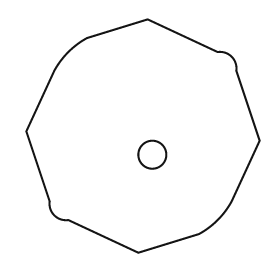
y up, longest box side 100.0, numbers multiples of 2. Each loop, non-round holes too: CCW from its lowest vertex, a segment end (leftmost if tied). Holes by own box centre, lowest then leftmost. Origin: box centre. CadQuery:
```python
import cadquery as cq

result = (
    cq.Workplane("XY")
    .moveTo(-2.0, -50.0)
    .lineTo(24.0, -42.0)
    .threePointArc((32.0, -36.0), (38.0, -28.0))
    .lineTo(50.0, -2.0)
    .lineTo(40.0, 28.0)
    .threePointArc((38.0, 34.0), (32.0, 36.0))
    .lineTo(2.0, 50.0)
    .lineTo(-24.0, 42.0)
    .threePointArc((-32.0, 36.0), (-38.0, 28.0))
    .lineTo(-50.0, 2.0)
    .lineTo(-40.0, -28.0)
    .threePointArc((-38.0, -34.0), (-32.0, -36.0))
    .close()
    .moveTo(4.0, -8.0)
    .circle(6.0)
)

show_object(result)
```